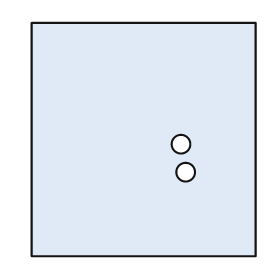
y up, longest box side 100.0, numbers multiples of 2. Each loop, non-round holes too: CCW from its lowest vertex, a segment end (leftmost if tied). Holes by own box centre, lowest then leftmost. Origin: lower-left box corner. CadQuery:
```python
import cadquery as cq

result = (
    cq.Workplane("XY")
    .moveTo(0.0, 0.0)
    .lineTo(96.0, 0.0)
    .lineTo(96.0, 100.0)
    .lineTo(0.0, 100.0)
    .close()
    .moveTo(66.0, 36.0)
    .circle(4.0)
    .moveTo(64.0, 48.0)
    .circle(4.0)
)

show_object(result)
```